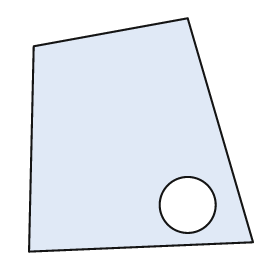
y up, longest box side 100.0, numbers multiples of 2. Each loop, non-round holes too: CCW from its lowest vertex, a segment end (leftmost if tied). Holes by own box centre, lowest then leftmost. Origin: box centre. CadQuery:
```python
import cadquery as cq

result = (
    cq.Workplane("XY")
    .moveTo(-48.0, -50.0)
    .lineTo(48.0, -46.0)
    .lineTo(20.0, 50.0)
    .lineTo(-46.0, 38.0)
    .close()
    .moveTo(20.0, -30.0)
    .circle(12.0)
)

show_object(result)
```